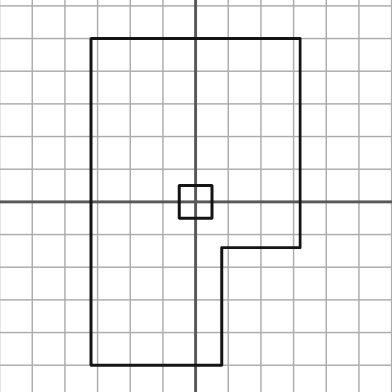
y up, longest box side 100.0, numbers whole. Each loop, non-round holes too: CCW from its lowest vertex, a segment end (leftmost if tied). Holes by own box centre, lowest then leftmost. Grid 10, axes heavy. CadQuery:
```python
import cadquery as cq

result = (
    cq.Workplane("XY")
    .moveTo(-32.0, -50.0)
    .lineTo(8.0, -50.0)
    .lineTo(8.0, -14.0)
    .lineTo(32.0, -14.0)
    .lineTo(32.0, 50.0)
    .lineTo(-32.0, 50.0)
    .close()
    .moveTo(-5.0, -5.0)
    .lineTo(5.0, -5.0)
    .lineTo(5.0, 5.0)
    .lineTo(-5.0, 5.0)
    .close()
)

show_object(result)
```